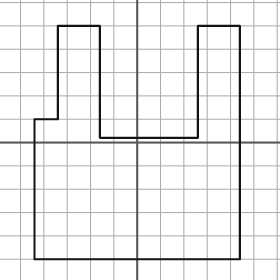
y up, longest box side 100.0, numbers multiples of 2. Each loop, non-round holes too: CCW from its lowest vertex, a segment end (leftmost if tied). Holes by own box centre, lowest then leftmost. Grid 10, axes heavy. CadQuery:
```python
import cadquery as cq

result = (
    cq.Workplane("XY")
    .moveTo(-44.0, -50.0)
    .lineTo(44.0, -50.0)
    .lineTo(44.0, 50.0)
    .lineTo(26.0, 50.0)
    .lineTo(26.0, 2.0)
    .lineTo(-16.0, 2.0)
    .lineTo(-16.0, 50.0)
    .lineTo(-34.0, 50.0)
    .lineTo(-34.0, 10.0)
    .lineTo(-44.0, 10.0)
    .close()
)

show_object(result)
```